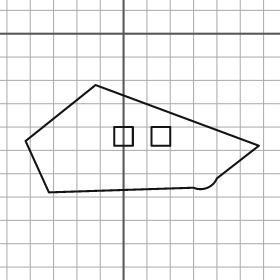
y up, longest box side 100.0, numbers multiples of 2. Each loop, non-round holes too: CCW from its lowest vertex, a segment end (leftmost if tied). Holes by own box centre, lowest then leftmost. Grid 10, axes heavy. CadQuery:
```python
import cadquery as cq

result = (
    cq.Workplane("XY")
    .moveTo(-32.0, -68.0)
    .lineTo(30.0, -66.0)
    .threePointArc((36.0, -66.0), (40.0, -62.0))
    .lineTo(58.0, -48.0)
    .lineTo(-12.0, -22.0)
    .lineTo(-42.0, -46.0)
    .close()
    .moveTo(-4.0, -48.0)
    .lineTo(4.0, -48.0)
    .lineTo(4.0, -40.0)
    .lineTo(-4.0, -40.0)
    .close()
    .moveTo(12.0, -48.0)
    .lineTo(20.0, -48.0)
    .lineTo(20.0, -40.0)
    .lineTo(12.0, -40.0)
    .close()
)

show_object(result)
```